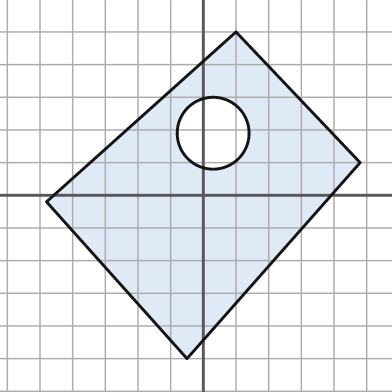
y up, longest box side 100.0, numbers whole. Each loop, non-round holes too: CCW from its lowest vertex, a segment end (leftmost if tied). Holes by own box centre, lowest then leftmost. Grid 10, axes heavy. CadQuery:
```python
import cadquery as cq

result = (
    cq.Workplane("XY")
    .moveTo(-5.0, -50.0)
    .lineTo(48.0, 10.0)
    .lineTo(10.0, 50.0)
    .lineTo(-48.0, -2.0)
    .close()
    .moveTo(3.0, 19.0)
    .circle(11.0)
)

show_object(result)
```